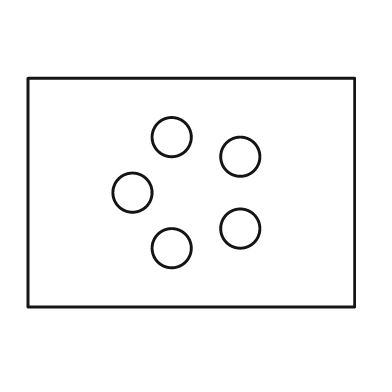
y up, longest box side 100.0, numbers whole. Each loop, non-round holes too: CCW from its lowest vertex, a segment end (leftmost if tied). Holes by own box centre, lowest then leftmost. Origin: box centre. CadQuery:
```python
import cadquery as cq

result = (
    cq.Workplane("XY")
    .moveTo(-50.0, -35.0)
    .lineTo(50.0, -35.0)
    .lineTo(50.0, 35.0)
    .lineTo(-50.0, 35.0)
    .close()
    .moveTo(-6.0, -17.0)
    .circle(6.0)
    .moveTo(15.0, -11.0)
    .circle(6.0)
    .moveTo(-18.0, 0.0)
    .circle(6.0)
    .moveTo(15.0, 11.0)
    .circle(6.0)
    .moveTo(-6.0, 17.0)
    .circle(6.0)
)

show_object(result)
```